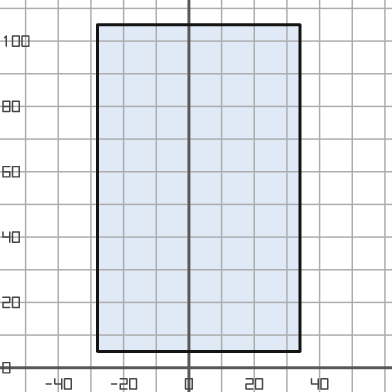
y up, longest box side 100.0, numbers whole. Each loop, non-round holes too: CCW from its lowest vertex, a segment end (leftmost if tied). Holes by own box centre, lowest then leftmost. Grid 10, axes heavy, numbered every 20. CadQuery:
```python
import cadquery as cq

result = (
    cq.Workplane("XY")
    .moveTo(-28.0, 5.0)
    .lineTo(34.0, 5.0)
    .lineTo(34.0, 105.0)
    .lineTo(-28.0, 105.0)
    .close()
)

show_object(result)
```